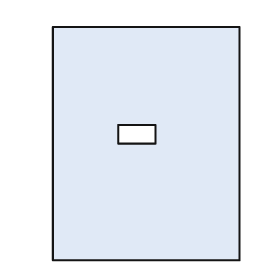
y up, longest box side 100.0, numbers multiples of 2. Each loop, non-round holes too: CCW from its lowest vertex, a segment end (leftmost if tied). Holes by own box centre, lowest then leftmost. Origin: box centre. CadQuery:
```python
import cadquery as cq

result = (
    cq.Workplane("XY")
    .moveTo(-40.0, -50.0)
    .lineTo(40.0, -50.0)
    .lineTo(40.0, 50.0)
    .lineTo(-40.0, 50.0)
    .close()
    .moveTo(-12.0, 0.0)
    .lineTo(4.0, 0.0)
    .lineTo(4.0, 8.0)
    .lineTo(-12.0, 8.0)
    .close()
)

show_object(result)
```